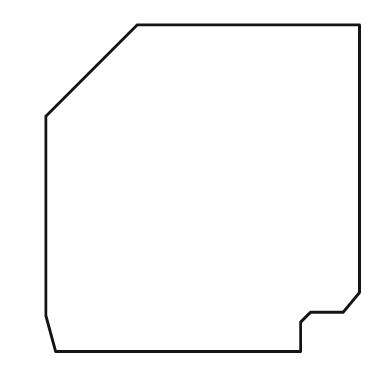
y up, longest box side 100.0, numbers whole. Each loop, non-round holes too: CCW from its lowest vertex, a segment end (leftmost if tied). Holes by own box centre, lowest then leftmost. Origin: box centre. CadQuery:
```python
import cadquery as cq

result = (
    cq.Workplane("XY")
    .moveTo(-45.0, -50.0)
    .lineTo(30.0, -50.0)
    .lineTo(30.0, -41.0)
    .lineTo(33.0, -38.0)
    .lineTo(43.0, -38.0)
    .lineTo(48.0, -32.0)
    .lineTo(48.0, 50.0)
    .lineTo(-20.0, 50.0)
    .lineTo(-48.0, 22.0)
    .lineTo(-48.0, -39.0)
    .close()
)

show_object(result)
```